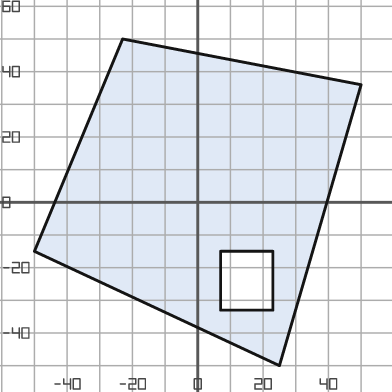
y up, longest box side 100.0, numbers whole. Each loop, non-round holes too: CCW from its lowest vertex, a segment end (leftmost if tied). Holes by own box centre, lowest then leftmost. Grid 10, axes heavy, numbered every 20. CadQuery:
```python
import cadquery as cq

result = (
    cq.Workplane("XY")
    .moveTo(25.0, -50.0)
    .lineTo(50.0, 36.0)
    .lineTo(-23.0, 50.0)
    .lineTo(-50.0, -15.0)
    .close()
    .moveTo(7.0, -33.0)
    .lineTo(23.0, -33.0)
    .lineTo(23.0, -15.0)
    .lineTo(7.0, -15.0)
    .close()
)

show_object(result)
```